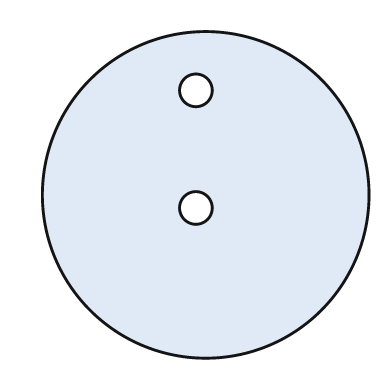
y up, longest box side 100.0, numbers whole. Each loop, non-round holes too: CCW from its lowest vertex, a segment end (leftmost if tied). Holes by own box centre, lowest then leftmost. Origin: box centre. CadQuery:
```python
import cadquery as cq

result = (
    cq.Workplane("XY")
    .moveTo(0.0, 0.0)
    .circle(50.0)
    .moveTo(-3.0, -4.0)
    .circle(5.0)
    .moveTo(-3.0, 32.0)
    .circle(5.0)
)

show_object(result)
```